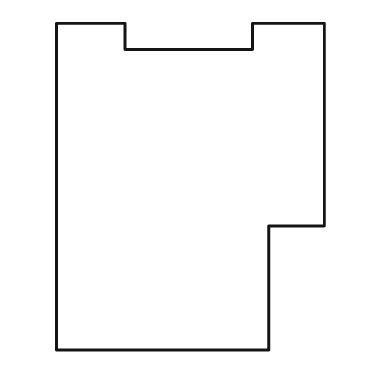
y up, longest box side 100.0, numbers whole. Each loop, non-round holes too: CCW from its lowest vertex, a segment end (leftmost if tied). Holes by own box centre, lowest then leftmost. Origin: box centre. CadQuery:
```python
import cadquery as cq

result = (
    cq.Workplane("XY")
    .moveTo(-41.0, -50.0)
    .lineTo(24.0, -50.0)
    .lineTo(24.0, -12.0)
    .lineTo(41.0, -12.0)
    .lineTo(41.0, 50.0)
    .lineTo(19.0, 50.0)
    .lineTo(19.0, 42.0)
    .lineTo(-20.0, 42.0)
    .lineTo(-20.0, 50.0)
    .lineTo(-41.0, 50.0)
    .close()
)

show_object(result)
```